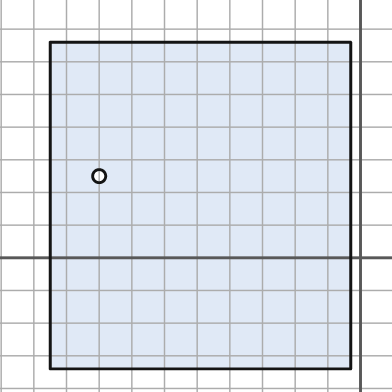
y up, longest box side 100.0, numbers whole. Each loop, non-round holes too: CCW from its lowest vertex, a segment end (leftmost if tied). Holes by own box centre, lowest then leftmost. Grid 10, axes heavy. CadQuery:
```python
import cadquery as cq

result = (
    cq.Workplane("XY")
    .moveTo(-95.0, -34.0)
    .lineTo(-3.0, -34.0)
    .lineTo(-3.0, 66.0)
    .lineTo(-95.0, 66.0)
    .close()
    .moveTo(-80.0, 25.0)
    .circle(2.0)
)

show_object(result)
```